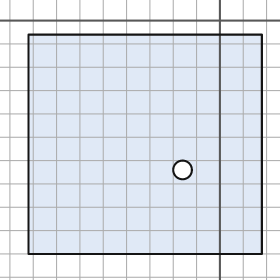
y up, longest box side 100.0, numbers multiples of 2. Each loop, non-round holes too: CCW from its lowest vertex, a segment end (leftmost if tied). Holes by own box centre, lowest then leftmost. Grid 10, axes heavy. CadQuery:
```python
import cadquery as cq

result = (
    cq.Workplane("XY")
    .moveTo(-82.0, -100.0)
    .lineTo(18.0, -100.0)
    .lineTo(18.0, -6.0)
    .lineTo(-82.0, -6.0)
    .close()
    .moveTo(-16.0, -64.0)
    .circle(4.0)
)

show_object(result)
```